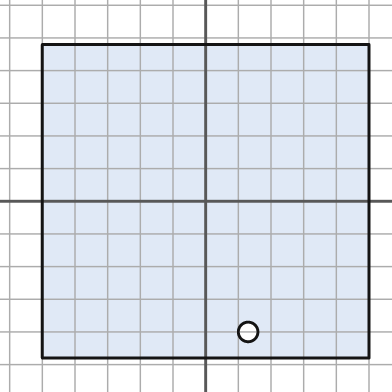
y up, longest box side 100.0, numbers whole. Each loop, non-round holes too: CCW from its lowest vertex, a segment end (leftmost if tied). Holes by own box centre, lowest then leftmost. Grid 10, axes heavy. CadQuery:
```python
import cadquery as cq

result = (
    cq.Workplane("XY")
    .moveTo(-50.0, -48.0)
    .lineTo(50.0, -48.0)
    .lineTo(50.0, 48.0)
    .lineTo(-50.0, 48.0)
    .close()
    .moveTo(13.0, -40.0)
    .circle(3.0)
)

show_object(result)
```